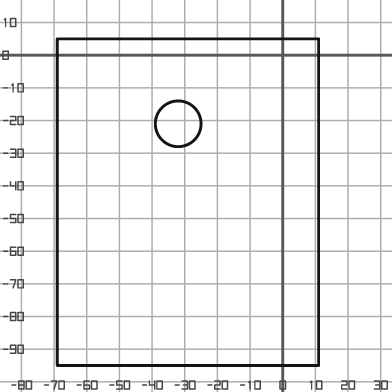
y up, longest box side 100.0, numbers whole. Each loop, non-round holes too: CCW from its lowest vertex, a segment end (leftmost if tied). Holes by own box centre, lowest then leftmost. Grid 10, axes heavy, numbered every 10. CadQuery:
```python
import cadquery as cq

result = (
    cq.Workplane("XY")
    .moveTo(-69.0, -95.0)
    .lineTo(11.0, -95.0)
    .lineTo(11.0, 5.0)
    .lineTo(-69.0, 5.0)
    .close()
    .moveTo(-32.0, -21.0)
    .circle(7.0)
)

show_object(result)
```